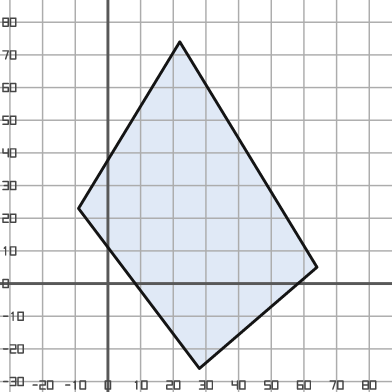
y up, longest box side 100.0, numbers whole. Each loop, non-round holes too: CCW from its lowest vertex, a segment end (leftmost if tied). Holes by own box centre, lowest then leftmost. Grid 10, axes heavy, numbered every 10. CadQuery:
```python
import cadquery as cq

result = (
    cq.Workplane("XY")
    .moveTo(28.0, -26.0)
    .lineTo(64.0, 5.0)
    .lineTo(22.0, 74.0)
    .lineTo(-9.0, 23.0)
    .close()
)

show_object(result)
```